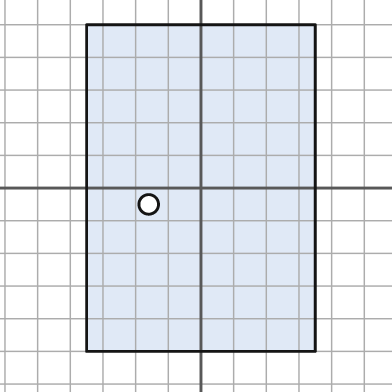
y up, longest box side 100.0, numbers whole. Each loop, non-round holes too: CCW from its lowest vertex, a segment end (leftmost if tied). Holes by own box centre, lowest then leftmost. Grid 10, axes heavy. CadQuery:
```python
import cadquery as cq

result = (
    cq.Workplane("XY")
    .moveTo(-35.0, -50.0)
    .lineTo(35.0, -50.0)
    .lineTo(35.0, 50.0)
    .lineTo(-35.0, 50.0)
    .close()
    .moveTo(-16.0, -5.0)
    .circle(3.0)
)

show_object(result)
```